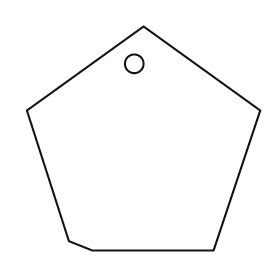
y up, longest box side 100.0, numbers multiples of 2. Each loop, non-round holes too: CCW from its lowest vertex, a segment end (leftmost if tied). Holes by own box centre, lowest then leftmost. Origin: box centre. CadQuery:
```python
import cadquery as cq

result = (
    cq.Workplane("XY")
    .moveTo(-22.0, -48.0)
    .lineTo(30.0, -48.0)
    .lineTo(50.0, 12.0)
    .lineTo(0.0, 48.0)
    .lineTo(-50.0, 12.0)
    .lineTo(-32.0, -44.0)
    .close()
    .moveTo(-4.0, 32.0)
    .circle(4.0)
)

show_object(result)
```